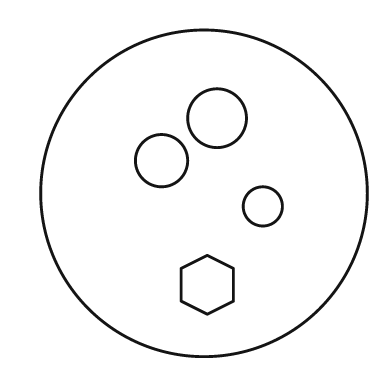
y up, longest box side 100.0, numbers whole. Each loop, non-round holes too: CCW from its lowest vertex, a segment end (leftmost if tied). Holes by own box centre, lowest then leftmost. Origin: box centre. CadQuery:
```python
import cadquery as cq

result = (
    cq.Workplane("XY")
    .moveTo(0.0, 0.0)
    .circle(50.0)
    .moveTo(1.0, -37.0)
    .lineTo(9.0, -33.0)
    .lineTo(9.0, -23.0)
    .lineTo(1.0, -19.0)
    .lineTo(-7.0, -23.0)
    .lineTo(-7.0, -33.0)
    .close()
    .moveTo(18.0, -4.0)
    .circle(6.0)
    .moveTo(-13.0, 10.0)
    .circle(8.0)
    .moveTo(4.0, 23.0)
    .circle(9.0)
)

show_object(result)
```